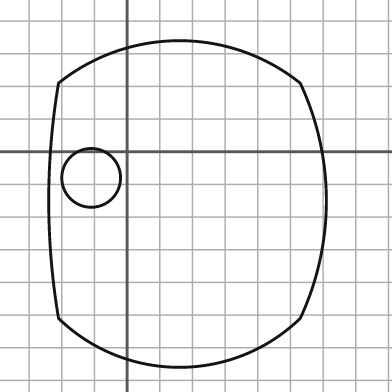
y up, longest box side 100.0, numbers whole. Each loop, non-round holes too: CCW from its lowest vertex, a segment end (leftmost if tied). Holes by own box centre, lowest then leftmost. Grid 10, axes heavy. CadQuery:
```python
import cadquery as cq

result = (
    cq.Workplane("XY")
    .moveTo(-21.0, -51.0)
    .threePointArc((16.0, -66.0), (53.0, -51.0))
    .threePointArc((61.0, -15.0), (53.0, 21.0))
    .threePointArc((16.0, 34.0), (-21.0, 21.0))
    .threePointArc((-24.0, -15.0), (-21.0, -51.0))
    .close()
    .moveTo(-11.0, -8.0)
    .circle(9.0)
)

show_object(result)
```